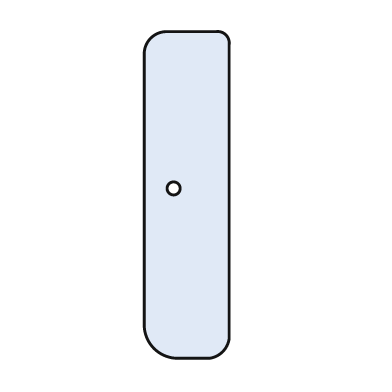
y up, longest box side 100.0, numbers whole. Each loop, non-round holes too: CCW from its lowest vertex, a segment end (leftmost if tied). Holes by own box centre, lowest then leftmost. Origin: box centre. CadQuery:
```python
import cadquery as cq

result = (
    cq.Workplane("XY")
    .moveTo(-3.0, -50.0)
    .lineTo(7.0, -50.0)
    .threePointArc((11.0, -48.0), (13.0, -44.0))
    .lineTo(13.0, 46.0)
    .threePointArc((12.0, 49.0), (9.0, 50.0))
    .lineTo(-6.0, 50.0)
    .threePointArc((-11.0, 48.0), (-13.0, 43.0))
    .lineTo(-13.0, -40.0)
    .threePointArc((-10.0, -47.0), (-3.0, -50.0))
    .close()
    .moveTo(-4.0, 2.0)
    .circle(2.0)
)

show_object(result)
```